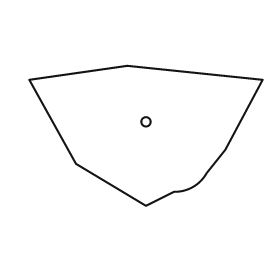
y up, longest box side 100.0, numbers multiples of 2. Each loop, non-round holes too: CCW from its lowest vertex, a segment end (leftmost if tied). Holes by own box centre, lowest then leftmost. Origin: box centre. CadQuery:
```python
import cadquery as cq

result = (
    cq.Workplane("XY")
    .moveTo(0.0, -30.0)
    .lineTo(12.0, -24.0)
    .threePointArc((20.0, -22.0), (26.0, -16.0))
    .lineTo(34.0, -6.0)
    .lineTo(50.0, 24.0)
    .lineTo(-8.0, 30.0)
    .lineTo(-50.0, 24.0)
    .lineTo(-30.0, -12.0)
    .close()
    .moveTo(0.0, 6.0)
    .circle(2.0)
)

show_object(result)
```